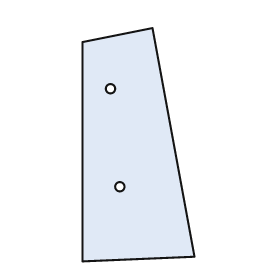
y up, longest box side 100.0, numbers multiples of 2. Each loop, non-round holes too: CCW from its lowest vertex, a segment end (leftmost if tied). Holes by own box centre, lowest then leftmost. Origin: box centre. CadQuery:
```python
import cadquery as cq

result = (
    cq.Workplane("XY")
    .moveTo(-24.0, -50.0)
    .lineTo(24.0, -48.0)
    .lineTo(6.0, 50.0)
    .lineTo(-24.0, 44.0)
    .close()
    .moveTo(-8.0, -18.0)
    .circle(2.0)
    .moveTo(-12.0, 24.0)
    .circle(2.0)
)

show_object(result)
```